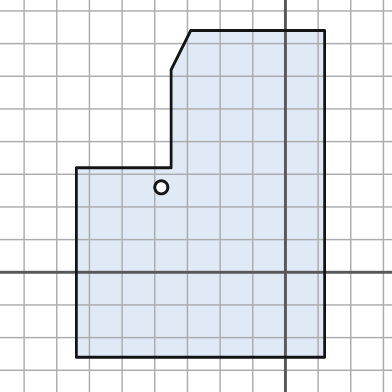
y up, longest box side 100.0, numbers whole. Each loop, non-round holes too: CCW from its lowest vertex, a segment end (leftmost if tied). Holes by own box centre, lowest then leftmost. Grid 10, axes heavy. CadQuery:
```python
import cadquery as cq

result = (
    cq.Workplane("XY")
    .moveTo(-64.0, -26.0)
    .lineTo(12.0, -26.0)
    .lineTo(12.0, 74.0)
    .lineTo(-29.0, 74.0)
    .lineTo(-35.0, 62.0)
    .lineTo(-35.0, 32.0)
    .lineTo(-64.0, 32.0)
    .close()
    .moveTo(-38.0, 26.0)
    .circle(2.0)
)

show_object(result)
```